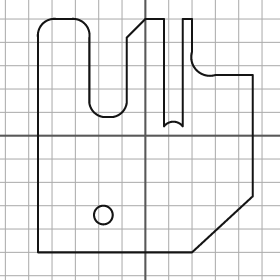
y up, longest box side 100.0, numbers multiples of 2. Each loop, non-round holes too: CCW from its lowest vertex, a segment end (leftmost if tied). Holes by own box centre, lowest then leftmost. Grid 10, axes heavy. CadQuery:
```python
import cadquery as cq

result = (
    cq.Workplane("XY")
    .moveTo(-46.0, -50.0)
    .lineTo(20.0, -50.0)
    .lineTo(46.0, -26.0)
    .lineTo(46.0, 26.0)
    .lineTo(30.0, 26.0)
    .threePointArc((22.0, 28.0), (20.0, 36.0))
    .lineTo(20.0, 50.0)
    .lineTo(16.0, 50.0)
    .lineTo(16.0, 4.0)
    .threePointArc((12.0, 6.0), (8.0, 4.0))
    .lineTo(8.0, 50.0)
    .lineTo(0.0, 50.0)
    .lineTo(-8.0, 42.0)
    .lineTo(-8.0, 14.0)
    .threePointArc((-10.0, 10.0), (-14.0, 8.0))
    .lineTo(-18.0, 8.0)
    .threePointArc((-22.0, 10.0), (-24.0, 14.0))
    .lineTo(-24.0, 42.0)
    .threePointArc((-26.0, 48.0), (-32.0, 50.0))
    .lineTo(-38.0, 50.0)
    .threePointArc((-44.0, 48.0), (-46.0, 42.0))
    .close()
    .moveTo(-18.0, -34.0)
    .circle(4.0)
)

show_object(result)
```